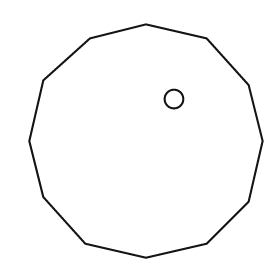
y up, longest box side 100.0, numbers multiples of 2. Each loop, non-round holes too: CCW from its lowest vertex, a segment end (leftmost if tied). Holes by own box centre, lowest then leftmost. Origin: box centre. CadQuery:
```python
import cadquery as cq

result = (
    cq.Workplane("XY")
    .moveTo(0.0, -50.0)
    .lineTo(26.0, -44.0)
    .lineTo(44.0, -26.0)
    .lineTo(50.0, 0.0)
    .lineTo(44.0, 24.0)
    .lineTo(26.0, 44.0)
    .lineTo(0.0, 50.0)
    .lineTo(-24.0, 44.0)
    .lineTo(-44.0, 26.0)
    .lineTo(-50.0, 0.0)
    .lineTo(-44.0, -24.0)
    .lineTo(-26.0, -44.0)
    .close()
    .moveTo(12.0, 18.0)
    .circle(4.0)
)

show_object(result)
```